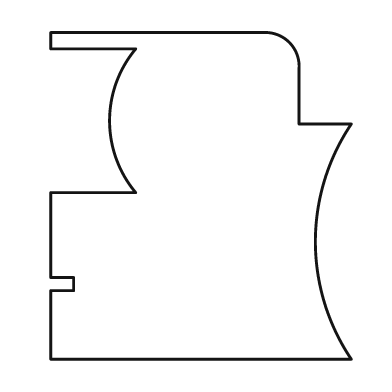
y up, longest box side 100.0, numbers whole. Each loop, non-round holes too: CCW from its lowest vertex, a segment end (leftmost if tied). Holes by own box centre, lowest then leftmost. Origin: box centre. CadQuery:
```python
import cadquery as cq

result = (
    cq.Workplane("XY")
    .moveTo(-46.0, -50.0)
    .lineTo(46.0, -50.0)
    .threePointArc((35.0, -14.0), (46.0, 22.0))
    .lineTo(30.0, 22.0)
    .lineTo(30.0, 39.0)
    .threePointArc((27.0, 47.0), (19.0, 50.0))
    .lineTo(-46.0, 50.0)
    .lineTo(-46.0, 45.0)
    .lineTo(-20.0, 45.0)
    .threePointArc((-28.0, 23.0), (-20.0, 1.0))
    .lineTo(-46.0, 1.0)
    .lineTo(-46.0, -25.0)
    .lineTo(-39.0, -25.0)
    .lineTo(-39.0, -29.0)
    .lineTo(-46.0, -29.0)
    .close()
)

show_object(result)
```